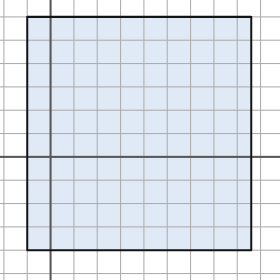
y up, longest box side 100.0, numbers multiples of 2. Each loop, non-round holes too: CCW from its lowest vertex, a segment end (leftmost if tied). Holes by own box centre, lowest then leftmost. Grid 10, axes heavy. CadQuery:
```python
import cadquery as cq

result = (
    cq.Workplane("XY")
    .moveTo(-10.0, -40.0)
    .lineTo(86.0, -40.0)
    .lineTo(86.0, 60.0)
    .lineTo(-10.0, 60.0)
    .close()
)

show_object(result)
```